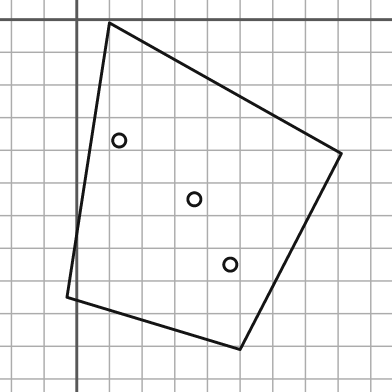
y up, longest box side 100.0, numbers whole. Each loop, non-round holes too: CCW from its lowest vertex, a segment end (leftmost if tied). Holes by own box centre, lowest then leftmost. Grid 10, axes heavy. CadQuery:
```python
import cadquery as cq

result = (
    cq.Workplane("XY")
    .moveTo(50.0, -101.0)
    .lineTo(81.0, -41.0)
    .lineTo(10.0, -1.0)
    .lineTo(-3.0, -85.0)
    .close()
    .moveTo(47.0, -75.0)
    .circle(2.0)
    .moveTo(36.0, -55.0)
    .circle(2.0)
    .moveTo(13.0, -37.0)
    .circle(2.0)
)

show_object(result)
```